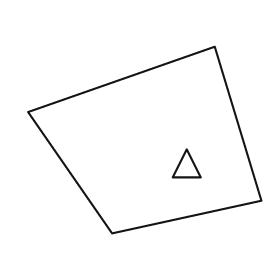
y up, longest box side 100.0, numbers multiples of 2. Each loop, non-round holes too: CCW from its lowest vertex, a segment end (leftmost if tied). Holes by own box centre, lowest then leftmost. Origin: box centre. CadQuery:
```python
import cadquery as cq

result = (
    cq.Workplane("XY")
    .moveTo(-14.0, -40.0)
    .lineTo(50.0, -26.0)
    .lineTo(30.0, 40.0)
    .lineTo(-50.0, 12.0)
    .close()
    .moveTo(12.0, -16.0)
    .lineTo(24.0, -16.0)
    .lineTo(18.0, -4.0)
    .close()
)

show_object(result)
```